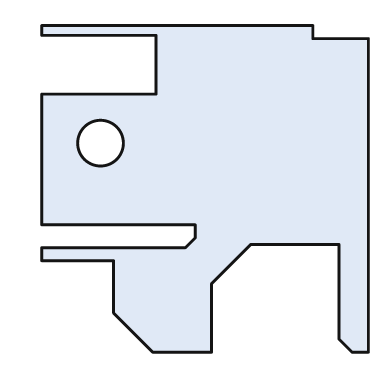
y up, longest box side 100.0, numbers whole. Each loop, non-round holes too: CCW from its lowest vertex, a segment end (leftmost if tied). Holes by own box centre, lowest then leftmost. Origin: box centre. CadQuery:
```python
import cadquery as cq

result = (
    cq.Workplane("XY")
    .moveTo(-16.0, -50.0)
    .lineTo(2.0, -50.0)
    .lineTo(2.0, -29.0)
    .lineTo(14.0, -17.0)
    .lineTo(41.0, -17.0)
    .lineTo(41.0, -46.0)
    .lineTo(45.0, -50.0)
    .lineTo(50.0, -50.0)
    .lineTo(50.0, 46.0)
    .lineTo(33.0, 46.0)
    .lineTo(33.0, 50.0)
    .lineTo(-50.0, 50.0)
    .lineTo(-50.0, 47.0)
    .lineTo(-15.0, 47.0)
    .lineTo(-15.0, 29.0)
    .lineTo(-50.0, 29.0)
    .lineTo(-50.0, -11.0)
    .lineTo(-3.0, -11.0)
    .lineTo(-3.0, -15.0)
    .lineTo(-6.0, -18.0)
    .lineTo(-50.0, -18.0)
    .lineTo(-50.0, -22.0)
    .lineTo(-28.0, -22.0)
    .lineTo(-28.0, -38.0)
    .close()
    .moveTo(-32.0, 14.0)
    .circle(7.0)
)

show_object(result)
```